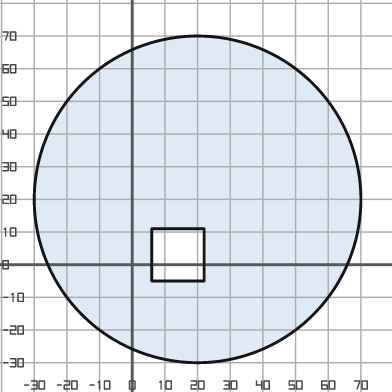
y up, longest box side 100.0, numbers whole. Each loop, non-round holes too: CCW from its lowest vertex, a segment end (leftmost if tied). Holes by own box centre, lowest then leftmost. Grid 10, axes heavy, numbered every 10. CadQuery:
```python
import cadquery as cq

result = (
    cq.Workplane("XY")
    .moveTo(20.0, 20.0)
    .circle(50.0)
    .moveTo(6.0, -5.0)
    .lineTo(22.0, -5.0)
    .lineTo(22.0, 11.0)
    .lineTo(6.0, 11.0)
    .close()
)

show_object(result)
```